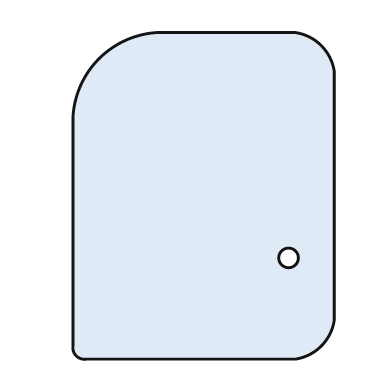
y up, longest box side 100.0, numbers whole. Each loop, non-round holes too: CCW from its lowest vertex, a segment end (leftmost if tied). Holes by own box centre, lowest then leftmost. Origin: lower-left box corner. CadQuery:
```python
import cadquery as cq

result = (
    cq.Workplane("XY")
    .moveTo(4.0, 0.0)
    .lineTo(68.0, 0.0)
    .threePointArc((76.0, 4.0), (80.0, 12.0))
    .lineTo(80.0, 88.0)
    .threePointArc((76.0, 96.0), (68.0, 100.0))
    .lineTo(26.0, 100.0)
    .threePointArc((8.0, 92.0), (0.0, 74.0))
    .lineTo(0.0, 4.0)
    .threePointArc((1.0, 1.0), (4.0, 0.0))
    .close()
    .moveTo(66.0, 31.0)
    .circle(3.0)
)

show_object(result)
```